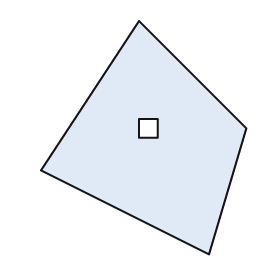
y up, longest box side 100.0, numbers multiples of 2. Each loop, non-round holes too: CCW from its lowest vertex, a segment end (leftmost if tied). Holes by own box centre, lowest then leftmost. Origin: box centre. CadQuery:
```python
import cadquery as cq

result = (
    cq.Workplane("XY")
    .moveTo(28.0, -50.0)
    .lineTo(44.0, 4.0)
    .lineTo(-2.0, 50.0)
    .lineTo(-44.0, -14.0)
    .close()
    .moveTo(-2.0, 0.0)
    .lineTo(6.0, 0.0)
    .lineTo(6.0, 8.0)
    .lineTo(-2.0, 8.0)
    .close()
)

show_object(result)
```